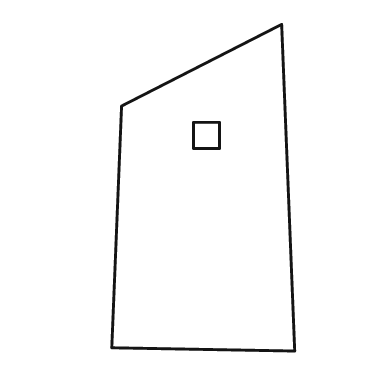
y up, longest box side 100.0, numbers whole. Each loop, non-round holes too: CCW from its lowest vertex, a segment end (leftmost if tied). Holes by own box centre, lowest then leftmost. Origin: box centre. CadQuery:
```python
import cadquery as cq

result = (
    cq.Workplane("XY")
    .moveTo(28.0, -50.0)
    .lineTo(24.0, 50.0)
    .lineTo(-25.0, 25.0)
    .lineTo(-28.0, -49.0)
    .close()
    .moveTo(-3.0, 12.0)
    .lineTo(5.0, 12.0)
    .lineTo(5.0, 20.0)
    .lineTo(-3.0, 20.0)
    .close()
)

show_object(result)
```